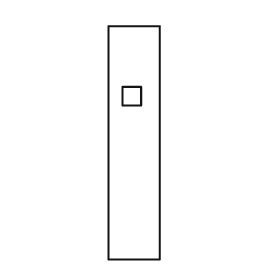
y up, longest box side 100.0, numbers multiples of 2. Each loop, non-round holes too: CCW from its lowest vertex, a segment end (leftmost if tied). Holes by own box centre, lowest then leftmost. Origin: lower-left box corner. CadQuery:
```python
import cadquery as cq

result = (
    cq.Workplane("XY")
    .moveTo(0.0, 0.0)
    .lineTo(22.0, 0.0)
    .lineTo(22.0, 100.0)
    .lineTo(0.0, 100.0)
    .close()
    .moveTo(6.0, 66.0)
    .lineTo(14.0, 66.0)
    .lineTo(14.0, 74.0)
    .lineTo(6.0, 74.0)
    .close()
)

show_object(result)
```